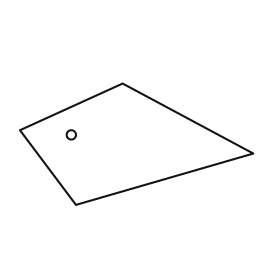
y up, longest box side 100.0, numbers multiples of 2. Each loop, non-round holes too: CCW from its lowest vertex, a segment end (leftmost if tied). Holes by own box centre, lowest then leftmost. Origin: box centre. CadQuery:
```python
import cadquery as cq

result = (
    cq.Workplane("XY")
    .moveTo(-26.0, -26.0)
    .lineTo(50.0, -4.0)
    .lineTo(-6.0, 26.0)
    .lineTo(-50.0, 6.0)
    .close()
    .moveTo(-28.0, 4.0)
    .circle(2.0)
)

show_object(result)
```